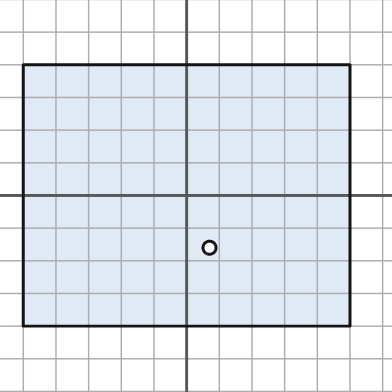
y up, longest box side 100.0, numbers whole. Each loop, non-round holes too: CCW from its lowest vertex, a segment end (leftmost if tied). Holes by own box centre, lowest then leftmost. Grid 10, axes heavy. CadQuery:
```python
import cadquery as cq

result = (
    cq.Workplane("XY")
    .moveTo(-50.0, -40.0)
    .lineTo(50.0, -40.0)
    .lineTo(50.0, 40.0)
    .lineTo(-50.0, 40.0)
    .close()
    .moveTo(7.0, -16.0)
    .circle(2.0)
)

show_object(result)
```